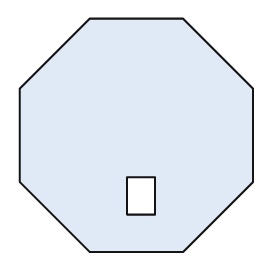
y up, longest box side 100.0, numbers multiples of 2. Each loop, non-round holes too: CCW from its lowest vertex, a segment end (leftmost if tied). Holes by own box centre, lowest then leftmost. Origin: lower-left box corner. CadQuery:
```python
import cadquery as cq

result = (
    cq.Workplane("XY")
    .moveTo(30.0, 0.0)
    .lineTo(70.0, 0.0)
    .lineTo(100.0, 30.0)
    .lineTo(100.0, 70.0)
    .lineTo(70.0, 100.0)
    .lineTo(30.0, 100.0)
    .lineTo(0.0, 70.0)
    .lineTo(0.0, 30.0)
    .close()
    .moveTo(46.0, 16.0)
    .lineTo(58.0, 16.0)
    .lineTo(58.0, 32.0)
    .lineTo(46.0, 32.0)
    .close()
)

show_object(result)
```